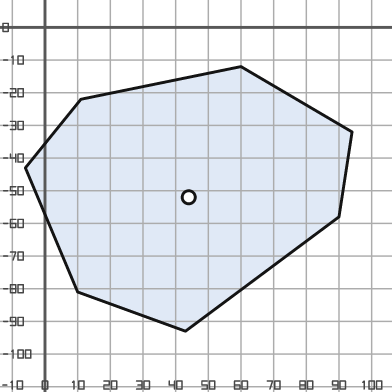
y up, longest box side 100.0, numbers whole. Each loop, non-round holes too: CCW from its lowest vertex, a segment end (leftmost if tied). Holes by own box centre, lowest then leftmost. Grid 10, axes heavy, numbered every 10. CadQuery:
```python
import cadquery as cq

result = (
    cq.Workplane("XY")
    .moveTo(43.0, -93.0)
    .lineTo(90.0, -58.0)
    .lineTo(94.0, -32.0)
    .lineTo(60.0, -12.0)
    .lineTo(11.0, -22.0)
    .lineTo(-6.0, -43.0)
    .lineTo(10.0, -81.0)
    .close()
    .moveTo(44.0, -52.0)
    .circle(2.0)
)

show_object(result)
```